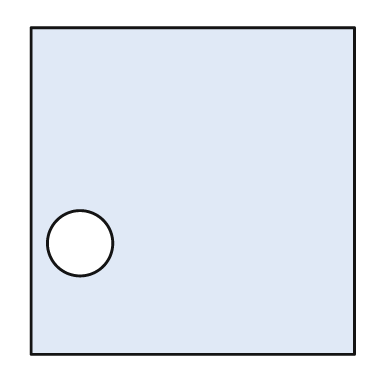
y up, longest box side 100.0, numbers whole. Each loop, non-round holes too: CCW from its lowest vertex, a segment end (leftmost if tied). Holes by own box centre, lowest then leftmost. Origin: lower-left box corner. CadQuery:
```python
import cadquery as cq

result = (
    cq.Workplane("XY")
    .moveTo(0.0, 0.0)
    .lineTo(99.0, 0.0)
    .lineTo(99.0, 100.0)
    .lineTo(0.0, 100.0)
    .close()
    .moveTo(15.0, 34.0)
    .circle(10.0)
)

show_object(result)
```